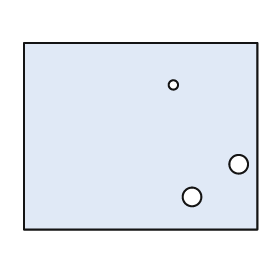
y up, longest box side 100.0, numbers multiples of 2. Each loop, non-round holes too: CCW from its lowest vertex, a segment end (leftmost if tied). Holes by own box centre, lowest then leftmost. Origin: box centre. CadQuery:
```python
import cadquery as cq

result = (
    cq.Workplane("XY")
    .moveTo(-50.0, -40.0)
    .lineTo(50.0, -40.0)
    .lineTo(50.0, 40.0)
    .lineTo(-50.0, 40.0)
    .close()
    .moveTo(22.0, -26.0)
    .circle(4.0)
    .moveTo(42.0, -12.0)
    .circle(4.0)
    .moveTo(14.0, 22.0)
    .circle(2.0)
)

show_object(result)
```